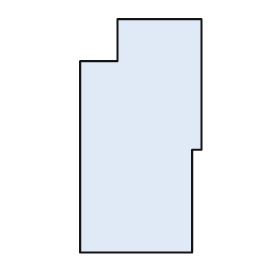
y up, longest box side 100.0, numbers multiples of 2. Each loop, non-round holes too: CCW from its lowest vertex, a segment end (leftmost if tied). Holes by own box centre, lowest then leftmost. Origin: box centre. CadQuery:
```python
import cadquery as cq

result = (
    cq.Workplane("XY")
    .moveTo(-26.0, -50.0)
    .lineTo(22.0, -50.0)
    .lineTo(22.0, -6.0)
    .lineTo(26.0, -6.0)
    .lineTo(26.0, 50.0)
    .lineTo(-10.0, 50.0)
    .lineTo(-10.0, 32.0)
    .lineTo(-26.0, 32.0)
    .close()
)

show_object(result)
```